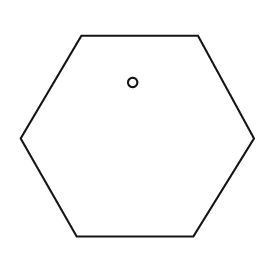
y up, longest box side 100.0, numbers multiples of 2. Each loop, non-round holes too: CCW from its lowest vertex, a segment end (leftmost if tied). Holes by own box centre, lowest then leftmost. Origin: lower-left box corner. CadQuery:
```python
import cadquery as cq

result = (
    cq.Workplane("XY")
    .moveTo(24.0, 0.0)
    .lineTo(74.0, 0.0)
    .lineTo(100.0, 42.0)
    .lineTo(76.0, 86.0)
    .lineTo(26.0, 86.0)
    .lineTo(0.0, 42.0)
    .close()
    .moveTo(48.0, 66.0)
    .circle(2.0)
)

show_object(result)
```